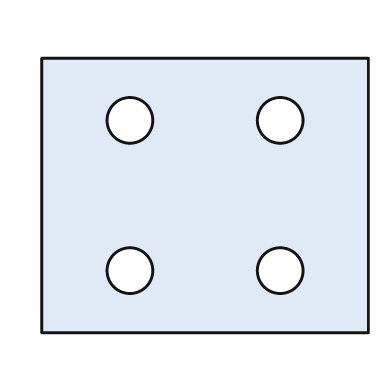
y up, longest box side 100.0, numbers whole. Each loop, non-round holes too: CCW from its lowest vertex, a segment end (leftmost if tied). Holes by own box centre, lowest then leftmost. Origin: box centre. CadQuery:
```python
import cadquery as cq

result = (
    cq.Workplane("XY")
    .moveTo(-50.0, -42.0)
    .lineTo(50.0, -42.0)
    .lineTo(50.0, 42.0)
    .lineTo(-50.0, 42.0)
    .close()
    .moveTo(-23.0, -23.0)
    .circle(7.0)
    .moveTo(23.0, -23.0)
    .circle(7.0)
    .moveTo(-23.0, 23.0)
    .circle(7.0)
    .moveTo(23.0, 23.0)
    .circle(7.0)
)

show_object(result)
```